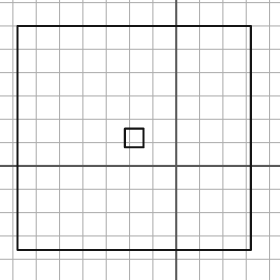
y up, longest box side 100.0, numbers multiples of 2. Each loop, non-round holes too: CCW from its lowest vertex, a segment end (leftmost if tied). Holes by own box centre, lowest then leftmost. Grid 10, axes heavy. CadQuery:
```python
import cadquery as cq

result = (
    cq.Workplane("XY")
    .moveTo(-68.0, -36.0)
    .lineTo(32.0, -36.0)
    .lineTo(32.0, 60.0)
    .lineTo(-68.0, 60.0)
    .close()
    .moveTo(-22.0, 8.0)
    .lineTo(-14.0, 8.0)
    .lineTo(-14.0, 16.0)
    .lineTo(-22.0, 16.0)
    .close()
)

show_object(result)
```